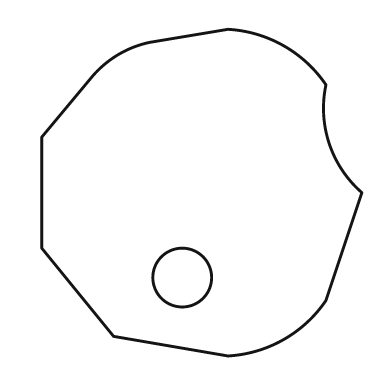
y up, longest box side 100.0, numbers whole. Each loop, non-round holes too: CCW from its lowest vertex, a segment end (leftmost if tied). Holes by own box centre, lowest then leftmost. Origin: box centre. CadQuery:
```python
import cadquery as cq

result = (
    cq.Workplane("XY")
    .moveTo(8.0, -50.0)
    .threePointArc((25.0, -45.0), (38.0, -33.0))
    .lineTo(49.0, 0.0)
    .threePointArc((39.0, 15.0), (38.0, 33.0))
    .threePointArc((25.0, 45.0), (8.0, 50.0))
    .lineTo(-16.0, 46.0)
    .threePointArc((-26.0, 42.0), (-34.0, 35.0))
    .lineTo(-49.0, 17.0)
    .lineTo(-49.0, -17.0)
    .lineTo(-27.0, -44.0)
    .close()
    .moveTo(-6.0, -26.0)
    .circle(9.0)
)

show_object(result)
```